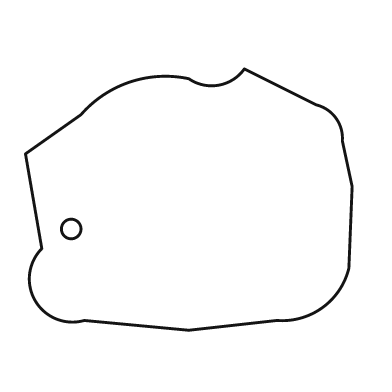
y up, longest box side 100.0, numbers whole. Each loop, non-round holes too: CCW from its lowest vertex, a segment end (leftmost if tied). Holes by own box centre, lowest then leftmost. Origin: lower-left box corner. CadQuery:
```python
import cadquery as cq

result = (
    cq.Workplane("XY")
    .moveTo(50.0, 0.0)
    .lineTo(77.0, 3.0)
    .threePointArc((91.0, 7.0), (99.0, 19.0))
    .lineTo(100.0, 44.0)
    .lineTo(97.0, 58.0)
    .threePointArc((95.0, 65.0), (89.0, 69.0))
    .lineTo(67.0, 80.0)
    .threePointArc((59.0, 75.0), (50.0, 77.0))
    .threePointArc((32.0, 76.0), (17.0, 66.0))
    .lineTo(0.0, 54.0)
    .lineTo(5.0, 25.0)
    .threePointArc((3.0, 9.0), (18.0, 3.0))
    .close()
    .moveTo(14.0, 31.0)
    .circle(3.0)
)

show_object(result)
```